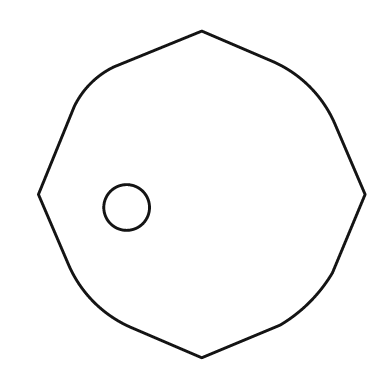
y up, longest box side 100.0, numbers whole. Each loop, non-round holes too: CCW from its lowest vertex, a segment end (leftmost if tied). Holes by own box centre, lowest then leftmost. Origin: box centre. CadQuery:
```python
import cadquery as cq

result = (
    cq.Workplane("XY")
    .moveTo(0.0, -50.0)
    .lineTo(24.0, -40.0)
    .threePointArc((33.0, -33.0), (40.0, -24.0))
    .lineTo(50.0, 0.0)
    .lineTo(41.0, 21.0)
    .threePointArc((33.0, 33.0), (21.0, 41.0))
    .lineTo(0.0, 50.0)
    .lineTo(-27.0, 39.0)
    .threePointArc((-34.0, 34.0), (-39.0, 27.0))
    .lineTo(-50.0, 0.0)
    .lineTo(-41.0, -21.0)
    .threePointArc((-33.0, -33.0), (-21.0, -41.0))
    .close()
    .moveTo(-23.0, -4.0)
    .circle(7.0)
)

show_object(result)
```